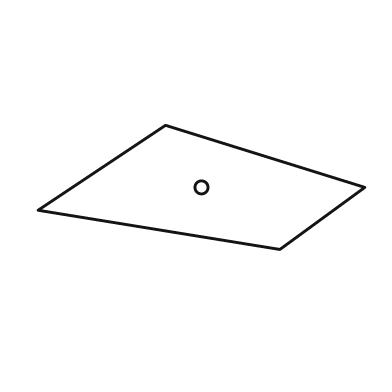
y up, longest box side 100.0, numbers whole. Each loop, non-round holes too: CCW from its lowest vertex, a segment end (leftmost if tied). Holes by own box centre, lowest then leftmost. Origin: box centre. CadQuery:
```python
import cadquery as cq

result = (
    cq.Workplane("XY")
    .moveTo(24.0, -19.0)
    .lineTo(50.0, 0.0)
    .lineTo(-11.0, 19.0)
    .lineTo(-50.0, -7.0)
    .close()
    .moveTo(0.0, 0.0)
    .circle(2.0)
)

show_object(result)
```